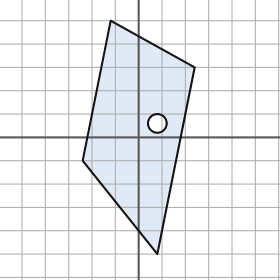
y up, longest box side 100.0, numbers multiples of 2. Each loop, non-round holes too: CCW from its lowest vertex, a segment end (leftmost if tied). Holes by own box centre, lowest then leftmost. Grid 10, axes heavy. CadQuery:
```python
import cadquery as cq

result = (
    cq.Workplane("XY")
    .moveTo(8.0, -50.0)
    .lineTo(24.0, 30.0)
    .lineTo(-12.0, 50.0)
    .lineTo(-24.0, -10.0)
    .close()
    .moveTo(8.0, 6.0)
    .circle(4.0)
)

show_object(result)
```